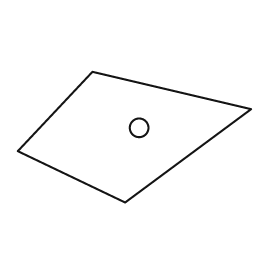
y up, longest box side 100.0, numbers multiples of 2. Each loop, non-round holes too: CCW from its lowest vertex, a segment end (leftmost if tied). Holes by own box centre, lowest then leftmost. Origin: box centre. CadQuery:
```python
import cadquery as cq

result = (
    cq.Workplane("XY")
    .moveTo(-4.0, -28.0)
    .lineTo(50.0, 12.0)
    .lineTo(-18.0, 28.0)
    .lineTo(-50.0, -6.0)
    .close()
    .moveTo(2.0, 4.0)
    .circle(4.0)
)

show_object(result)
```